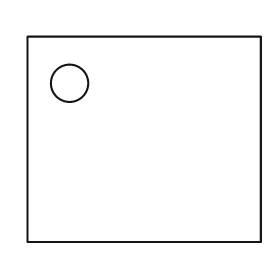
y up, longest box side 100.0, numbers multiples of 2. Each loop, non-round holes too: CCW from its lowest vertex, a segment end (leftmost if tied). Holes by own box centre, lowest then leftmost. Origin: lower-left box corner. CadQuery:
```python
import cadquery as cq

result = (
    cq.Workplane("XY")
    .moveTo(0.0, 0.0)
    .lineTo(100.0, 0.0)
    .lineTo(100.0, 88.0)
    .lineTo(0.0, 88.0)
    .close()
    .moveTo(18.0, 68.0)
    .circle(8.0)
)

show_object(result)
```